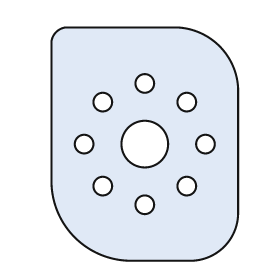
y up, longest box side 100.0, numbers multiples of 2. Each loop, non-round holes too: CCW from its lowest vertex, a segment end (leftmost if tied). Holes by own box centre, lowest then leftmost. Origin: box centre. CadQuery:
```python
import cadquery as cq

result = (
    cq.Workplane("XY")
    .moveTo(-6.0, -50.0)
    .lineTo(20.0, -50.0)
    .threePointArc((34.0, -44.0), (40.0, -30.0))
    .lineTo(40.0, 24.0)
    .threePointArc((32.0, 42.0), (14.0, 50.0))
    .lineTo(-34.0, 50.0)
    .threePointArc((-38.0, 48.0), (-40.0, 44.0))
    .lineTo(-40.0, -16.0)
    .threePointArc((-30.0, -40.0), (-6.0, -50.0))
    .close()
    .moveTo(0.0, -26.0)
    .circle(4.0)
    .moveTo(-18.0, -18.0)
    .circle(4.0)
    .moveTo(18.0, -18.0)
    .circle(4.0)
    .moveTo(-26.0, 0.0)
    .circle(4.0)
    .moveTo(0.0, 0.0)
    .circle(10.0)
    .moveTo(26.0, 0.0)
    .circle(4.0)
    .moveTo(-18.0, 18.0)
    .circle(4.0)
    .moveTo(18.0, 18.0)
    .circle(4.0)
    .moveTo(0.0, 26.0)
    .circle(4.0)
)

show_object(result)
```